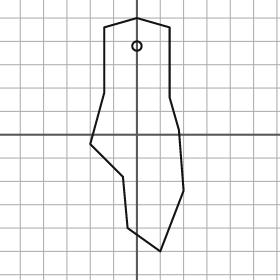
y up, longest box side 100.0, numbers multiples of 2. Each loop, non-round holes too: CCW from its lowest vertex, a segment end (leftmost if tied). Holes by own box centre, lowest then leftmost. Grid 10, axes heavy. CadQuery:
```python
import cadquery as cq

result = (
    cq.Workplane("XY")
    .moveTo(10.0, -50.0)
    .lineTo(20.0, -24.0)
    .lineTo(18.0, 2.0)
    .lineTo(14.0, 16.0)
    .lineTo(14.0, 46.0)
    .lineTo(0.0, 50.0)
    .lineTo(-14.0, 46.0)
    .lineTo(-14.0, 18.0)
    .lineTo(-20.0, -4.0)
    .lineTo(-6.0, -18.0)
    .lineTo(-4.0, -40.0)
    .close()
    .moveTo(0.0, 38.0)
    .circle(2.0)
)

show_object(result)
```